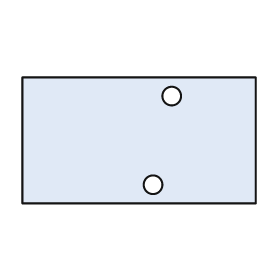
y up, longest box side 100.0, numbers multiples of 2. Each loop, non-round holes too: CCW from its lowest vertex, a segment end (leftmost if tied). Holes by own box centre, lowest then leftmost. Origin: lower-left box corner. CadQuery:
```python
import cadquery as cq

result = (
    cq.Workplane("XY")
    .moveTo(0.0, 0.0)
    .lineTo(100.0, 0.0)
    .lineTo(100.0, 54.0)
    .lineTo(0.0, 54.0)
    .close()
    .moveTo(56.0, 8.0)
    .circle(4.0)
    .moveTo(64.0, 46.0)
    .circle(4.0)
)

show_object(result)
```